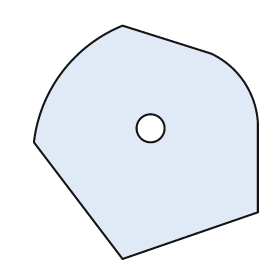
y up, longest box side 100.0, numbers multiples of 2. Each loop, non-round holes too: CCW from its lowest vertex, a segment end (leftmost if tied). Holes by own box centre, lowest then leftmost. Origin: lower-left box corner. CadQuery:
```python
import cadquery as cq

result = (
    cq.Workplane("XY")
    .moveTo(38.0, 0.0)
    .lineTo(96.0, 20.0)
    .lineTo(96.0, 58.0)
    .threePointArc((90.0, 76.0), (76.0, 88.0))
    .lineTo(38.0, 100.0)
    .threePointArc((12.0, 80.0), (0.0, 50.0))
    .close()
    .moveTo(50.0, 56.0)
    .circle(6.0)
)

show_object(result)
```